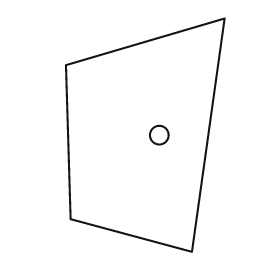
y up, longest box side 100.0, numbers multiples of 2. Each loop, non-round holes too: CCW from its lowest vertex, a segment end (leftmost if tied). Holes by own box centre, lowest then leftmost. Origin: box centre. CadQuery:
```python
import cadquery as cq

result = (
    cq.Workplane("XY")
    .moveTo(20.0, -50.0)
    .lineTo(34.0, 50.0)
    .lineTo(-34.0, 30.0)
    .lineTo(-32.0, -36.0)
    .close()
    .moveTo(6.0, 0.0)
    .circle(4.0)
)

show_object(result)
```